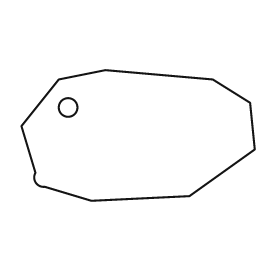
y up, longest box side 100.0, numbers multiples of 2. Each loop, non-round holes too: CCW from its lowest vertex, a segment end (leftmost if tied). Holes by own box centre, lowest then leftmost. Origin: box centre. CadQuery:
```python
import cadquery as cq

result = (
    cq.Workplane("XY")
    .moveTo(-20.0, -28.0)
    .lineTo(22.0, -26.0)
    .lineTo(50.0, -6.0)
    .lineTo(48.0, 14.0)
    .lineTo(32.0, 24.0)
    .lineTo(-14.0, 28.0)
    .lineTo(-34.0, 24.0)
    .lineTo(-50.0, 4.0)
    .lineTo(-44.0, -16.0)
    .threePointArc((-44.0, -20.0), (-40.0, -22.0))
    .close()
    .moveTo(-30.0, 12.0)
    .circle(4.0)
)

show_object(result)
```